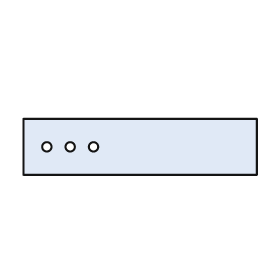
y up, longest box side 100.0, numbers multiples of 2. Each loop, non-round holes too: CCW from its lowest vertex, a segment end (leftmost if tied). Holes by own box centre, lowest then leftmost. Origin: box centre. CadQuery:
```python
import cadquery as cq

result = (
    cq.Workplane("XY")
    .moveTo(-50.0, -12.0)
    .lineTo(50.0, -12.0)
    .lineTo(50.0, 12.0)
    .lineTo(-50.0, 12.0)
    .close()
    .moveTo(-40.0, 0.0)
    .circle(2.0)
    .moveTo(-30.0, 0.0)
    .circle(2.0)
    .moveTo(-20.0, 0.0)
    .circle(2.0)
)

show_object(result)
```